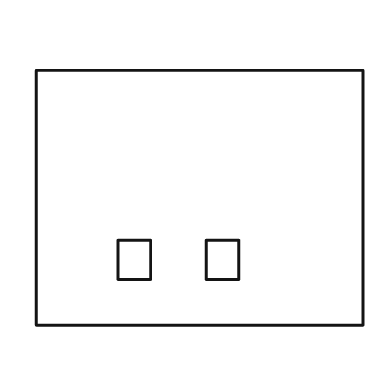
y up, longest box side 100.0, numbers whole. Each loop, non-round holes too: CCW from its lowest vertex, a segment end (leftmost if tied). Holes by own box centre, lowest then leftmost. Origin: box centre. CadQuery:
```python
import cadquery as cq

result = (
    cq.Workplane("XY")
    .moveTo(-50.0, -39.0)
    .lineTo(50.0, -39.0)
    .lineTo(50.0, 39.0)
    .lineTo(-50.0, 39.0)
    .close()
    .moveTo(-25.0, -25.0)
    .lineTo(-15.0, -25.0)
    .lineTo(-15.0, -13.0)
    .lineTo(-25.0, -13.0)
    .close()
    .moveTo(2.0, -25.0)
    .lineTo(12.0, -25.0)
    .lineTo(12.0, -13.0)
    .lineTo(2.0, -13.0)
    .close()
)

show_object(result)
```